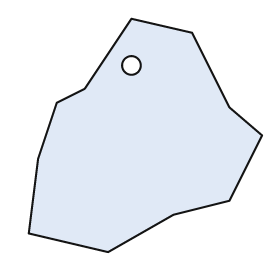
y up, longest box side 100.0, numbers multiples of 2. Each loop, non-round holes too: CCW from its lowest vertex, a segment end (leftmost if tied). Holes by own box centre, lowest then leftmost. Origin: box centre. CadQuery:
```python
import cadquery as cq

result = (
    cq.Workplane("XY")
    .moveTo(-16.0, -50.0)
    .lineTo(12.0, -34.0)
    .lineTo(36.0, -28.0)
    .lineTo(50.0, 0.0)
    .lineTo(36.0, 12.0)
    .lineTo(20.0, 44.0)
    .lineTo(-6.0, 50.0)
    .lineTo(-26.0, 20.0)
    .lineTo(-38.0, 14.0)
    .lineTo(-46.0, -10.0)
    .lineTo(-50.0, -42.0)
    .close()
    .moveTo(-6.0, 30.0)
    .circle(4.0)
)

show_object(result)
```